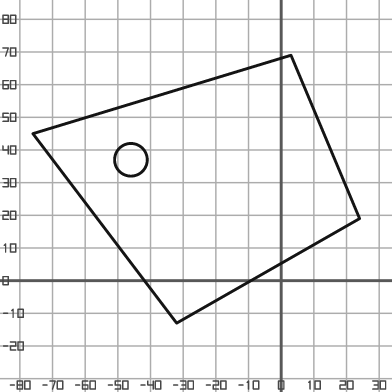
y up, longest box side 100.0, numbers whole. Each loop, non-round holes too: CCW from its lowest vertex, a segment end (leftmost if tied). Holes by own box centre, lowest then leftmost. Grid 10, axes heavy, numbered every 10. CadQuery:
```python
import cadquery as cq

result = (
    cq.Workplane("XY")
    .moveTo(-32.0, -13.0)
    .lineTo(24.0, 19.0)
    .lineTo(3.0, 69.0)
    .lineTo(-76.0, 45.0)
    .close()
    .moveTo(-46.0, 37.0)
    .circle(5.0)
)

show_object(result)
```